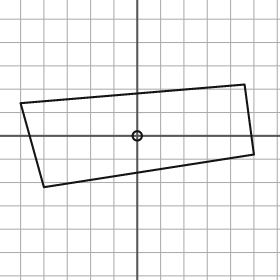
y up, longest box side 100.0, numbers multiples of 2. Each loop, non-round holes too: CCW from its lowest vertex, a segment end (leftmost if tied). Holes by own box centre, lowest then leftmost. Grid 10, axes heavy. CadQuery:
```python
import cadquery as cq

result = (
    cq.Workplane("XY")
    .moveTo(-40.0, -22.0)
    .lineTo(50.0, -8.0)
    .lineTo(46.0, 22.0)
    .lineTo(-50.0, 14.0)
    .close()
    .moveTo(0.0, 0.0)
    .circle(2.0)
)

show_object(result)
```